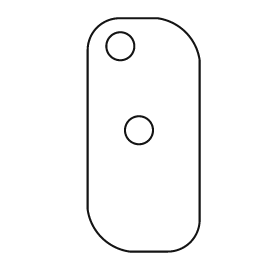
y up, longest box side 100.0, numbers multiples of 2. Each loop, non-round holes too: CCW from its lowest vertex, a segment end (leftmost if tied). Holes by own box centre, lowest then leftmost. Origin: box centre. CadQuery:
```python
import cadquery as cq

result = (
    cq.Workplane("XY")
    .moveTo(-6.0, -50.0)
    .lineTo(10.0, -50.0)
    .threePointArc((20.0, -46.0), (24.0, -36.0))
    .lineTo(24.0, 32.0)
    .threePointArc((18.0, 44.0), (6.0, 50.0))
    .lineTo(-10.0, 50.0)
    .threePointArc((-20.0, 46.0), (-24.0, 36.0))
    .lineTo(-24.0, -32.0)
    .threePointArc((-18.0, -44.0), (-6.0, -50.0))
    .close()
    .moveTo(-2.0, 2.0)
    .circle(6.0)
    .moveTo(-10.0, 38.0)
    .circle(6.0)
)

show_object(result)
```